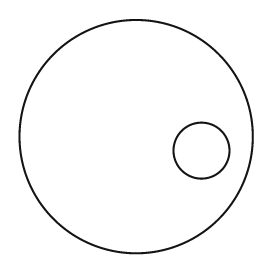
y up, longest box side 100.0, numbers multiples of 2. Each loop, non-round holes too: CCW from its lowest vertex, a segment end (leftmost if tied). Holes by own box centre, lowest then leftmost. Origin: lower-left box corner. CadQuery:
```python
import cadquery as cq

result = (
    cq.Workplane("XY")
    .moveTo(50.0, 50.0)
    .circle(50.0)
    .moveTo(78.0, 44.0)
    .circle(12.0)
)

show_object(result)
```